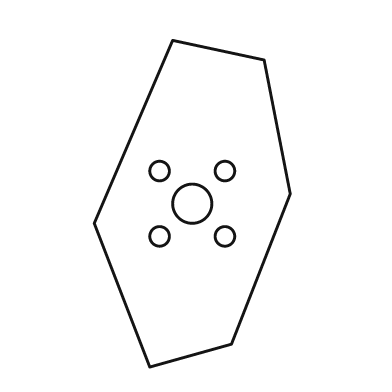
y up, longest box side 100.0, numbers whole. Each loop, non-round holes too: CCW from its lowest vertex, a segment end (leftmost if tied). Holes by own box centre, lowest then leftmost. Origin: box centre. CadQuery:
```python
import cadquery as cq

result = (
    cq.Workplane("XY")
    .moveTo(-13.0, -50.0)
    .lineTo(12.0, -43.0)
    .lineTo(30.0, 3.0)
    .lineTo(22.0, 44.0)
    .lineTo(-6.0, 50.0)
    .lineTo(-30.0, -6.0)
    .close()
    .moveTo(-10.0, -10.0)
    .circle(3.0)
    .moveTo(10.0, -10.0)
    .circle(3.0)
    .moveTo(0.0, 0.0)
    .circle(6.0)
    .moveTo(-10.0, 10.0)
    .circle(3.0)
    .moveTo(10.0, 10.0)
    .circle(3.0)
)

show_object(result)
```